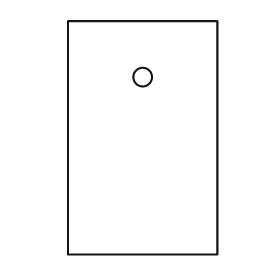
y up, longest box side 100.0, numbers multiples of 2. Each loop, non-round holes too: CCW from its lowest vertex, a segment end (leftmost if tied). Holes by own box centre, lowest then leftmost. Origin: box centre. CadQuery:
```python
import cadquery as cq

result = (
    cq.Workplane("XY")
    .moveTo(-32.0, -50.0)
    .lineTo(32.0, -50.0)
    .lineTo(32.0, 50.0)
    .lineTo(-32.0, 50.0)
    .close()
    .moveTo(0.0, 26.0)
    .circle(4.0)
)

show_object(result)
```